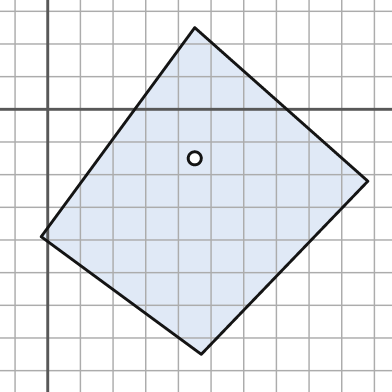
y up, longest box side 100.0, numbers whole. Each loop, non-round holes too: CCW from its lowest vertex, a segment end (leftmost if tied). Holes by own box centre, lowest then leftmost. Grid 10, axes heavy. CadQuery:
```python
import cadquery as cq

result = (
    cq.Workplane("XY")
    .moveTo(47.0, -75.0)
    .lineTo(98.0, -22.0)
    .lineTo(45.0, 25.0)
    .lineTo(-2.0, -39.0)
    .close()
    .moveTo(45.0, -15.0)
    .circle(2.0)
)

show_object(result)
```